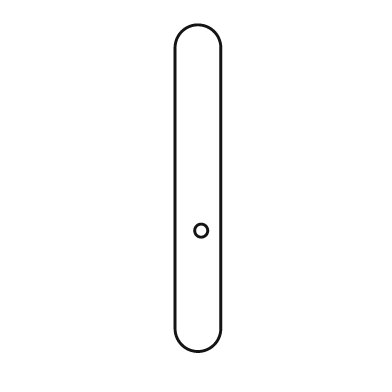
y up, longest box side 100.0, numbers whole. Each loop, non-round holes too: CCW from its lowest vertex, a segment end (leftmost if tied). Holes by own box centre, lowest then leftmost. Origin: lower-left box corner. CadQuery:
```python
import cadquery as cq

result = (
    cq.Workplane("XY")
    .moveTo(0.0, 7.0)
    .threePointArc((7.0, 0.0), (14.0, 7.0))
    .lineTo(14.0, 93.0)
    .threePointArc((7.0, 100.0), (0.0, 93.0))
    .close()
    .moveTo(8.0, 37.0)
    .circle(2.0)
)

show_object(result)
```